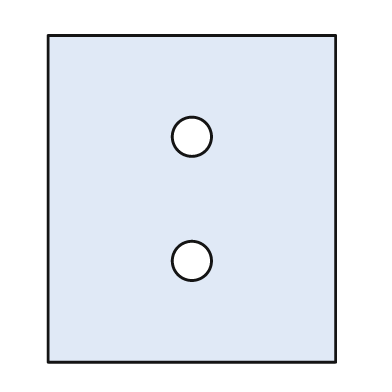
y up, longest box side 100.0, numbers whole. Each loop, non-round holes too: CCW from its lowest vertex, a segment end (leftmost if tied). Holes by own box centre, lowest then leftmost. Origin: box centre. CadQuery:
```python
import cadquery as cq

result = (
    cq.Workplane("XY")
    .moveTo(-44.0, -50.0)
    .lineTo(44.0, -50.0)
    .lineTo(44.0, 50.0)
    .lineTo(-44.0, 50.0)
    .close()
    .moveTo(0.0, -19.0)
    .circle(6.0)
    .moveTo(0.0, 19.0)
    .circle(6.0)
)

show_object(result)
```